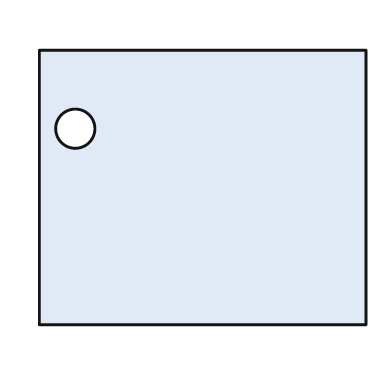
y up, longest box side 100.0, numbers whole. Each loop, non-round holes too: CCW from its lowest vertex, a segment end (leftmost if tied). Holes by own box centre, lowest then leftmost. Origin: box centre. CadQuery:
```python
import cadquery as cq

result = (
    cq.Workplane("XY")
    .moveTo(-50.0, -42.0)
    .lineTo(50.0, -42.0)
    .lineTo(50.0, 42.0)
    .lineTo(-50.0, 42.0)
    .close()
    .moveTo(-39.0, 18.0)
    .circle(6.0)
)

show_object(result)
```